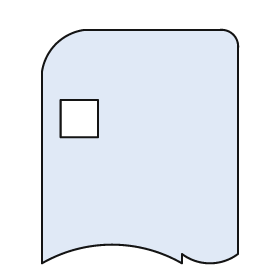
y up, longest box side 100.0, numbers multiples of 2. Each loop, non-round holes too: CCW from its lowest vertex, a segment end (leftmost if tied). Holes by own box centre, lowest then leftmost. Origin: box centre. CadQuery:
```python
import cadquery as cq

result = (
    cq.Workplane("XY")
    .moveTo(-42.0, -50.0)
    .threePointArc((-12.0, -42.0), (18.0, -50.0))
    .lineTo(18.0, -46.0)
    .threePointArc((30.0, -50.0), (42.0, -46.0))
    .lineTo(42.0, 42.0)
    .threePointArc((40.0, 48.0), (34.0, 50.0))
    .lineTo(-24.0, 50.0)
    .threePointArc((-36.0, 44.0), (-42.0, 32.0))
    .close()
    .moveTo(-34.0, 4.0)
    .lineTo(-18.0, 4.0)
    .lineTo(-18.0, 20.0)
    .lineTo(-34.0, 20.0)
    .close()
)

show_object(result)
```